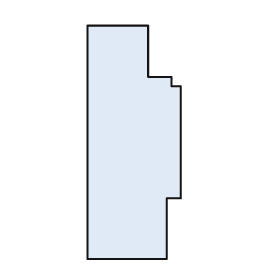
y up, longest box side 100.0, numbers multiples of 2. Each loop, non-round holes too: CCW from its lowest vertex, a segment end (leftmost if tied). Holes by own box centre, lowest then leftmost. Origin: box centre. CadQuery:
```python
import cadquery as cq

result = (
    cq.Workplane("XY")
    .moveTo(-20.0, -50.0)
    .lineTo(14.0, -50.0)
    .lineTo(14.0, -24.0)
    .lineTo(20.0, -24.0)
    .lineTo(20.0, 24.0)
    .lineTo(16.0, 24.0)
    .lineTo(16.0, 28.0)
    .lineTo(6.0, 28.0)
    .lineTo(6.0, 50.0)
    .lineTo(-20.0, 50.0)
    .close()
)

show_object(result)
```